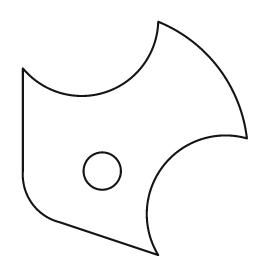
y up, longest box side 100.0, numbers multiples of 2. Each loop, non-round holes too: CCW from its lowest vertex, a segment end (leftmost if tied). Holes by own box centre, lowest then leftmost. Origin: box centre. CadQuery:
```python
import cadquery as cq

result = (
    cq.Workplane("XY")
    .moveTo(10.0, -50.0)
    .threePointArc((12.0, -12.0), (48.0, 0.0))
    .threePointArc((36.0, 30.0), (10.0, 50.0))
    .threePointArc((-12.0, 20.0), (-48.0, 30.0))
    .lineTo(-48.0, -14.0)
    .threePointArc((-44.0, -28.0), (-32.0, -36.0))
    .close()
    .moveTo(-14.0, -14.0)
    .circle(8.0)
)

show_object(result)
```